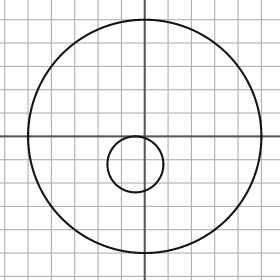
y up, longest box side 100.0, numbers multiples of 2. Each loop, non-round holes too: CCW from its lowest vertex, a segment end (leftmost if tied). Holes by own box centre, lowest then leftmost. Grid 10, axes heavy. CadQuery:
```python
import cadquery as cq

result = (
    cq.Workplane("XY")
    .moveTo(0.0, 0.0)
    .circle(50.0)
    .moveTo(-4.0, -12.0)
    .circle(12.0)
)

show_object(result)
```